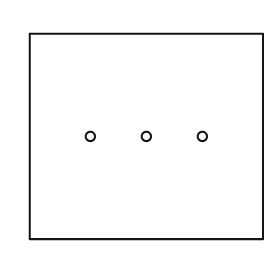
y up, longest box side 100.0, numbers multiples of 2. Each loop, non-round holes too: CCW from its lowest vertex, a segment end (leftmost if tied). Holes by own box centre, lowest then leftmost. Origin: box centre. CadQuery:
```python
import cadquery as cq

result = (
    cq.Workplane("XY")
    .moveTo(-50.0, -44.0)
    .lineTo(50.0, -44.0)
    .lineTo(50.0, 44.0)
    .lineTo(-50.0, 44.0)
    .close()
    .moveTo(-24.0, 0.0)
    .circle(2.0)
    .moveTo(0.0, 0.0)
    .circle(2.0)
    .moveTo(24.0, 0.0)
    .circle(2.0)
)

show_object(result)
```